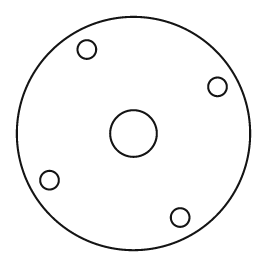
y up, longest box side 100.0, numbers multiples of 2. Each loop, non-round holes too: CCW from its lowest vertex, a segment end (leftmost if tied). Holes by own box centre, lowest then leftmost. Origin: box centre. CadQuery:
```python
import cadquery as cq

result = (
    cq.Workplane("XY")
    .moveTo(0.0, 0.0)
    .circle(50.0)
    .moveTo(20.0, -36.0)
    .circle(4.0)
    .moveTo(-36.0, -20.0)
    .circle(4.0)
    .moveTo(0.0, 0.0)
    .circle(10.0)
    .moveTo(36.0, 20.0)
    .circle(4.0)
    .moveTo(-20.0, 36.0)
    .circle(4.0)
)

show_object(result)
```